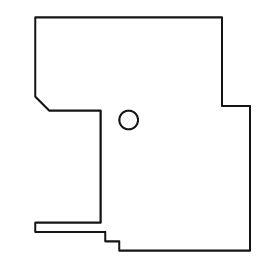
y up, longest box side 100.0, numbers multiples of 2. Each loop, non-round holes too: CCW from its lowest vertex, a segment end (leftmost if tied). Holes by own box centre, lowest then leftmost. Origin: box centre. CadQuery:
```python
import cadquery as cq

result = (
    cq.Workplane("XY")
    .moveTo(-10.0, -50.0)
    .lineTo(46.0, -50.0)
    .lineTo(46.0, 12.0)
    .lineTo(34.0, 12.0)
    .lineTo(34.0, 50.0)
    .lineTo(-46.0, 50.0)
    .lineTo(-46.0, 16.0)
    .lineTo(-40.0, 10.0)
    .lineTo(-18.0, 10.0)
    .lineTo(-18.0, -38.0)
    .lineTo(-46.0, -38.0)
    .lineTo(-46.0, -42.0)
    .lineTo(-16.0, -42.0)
    .lineTo(-16.0, -46.0)
    .lineTo(-10.0, -46.0)
    .close()
    .moveTo(-6.0, 6.0)
    .circle(4.0)
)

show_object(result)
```